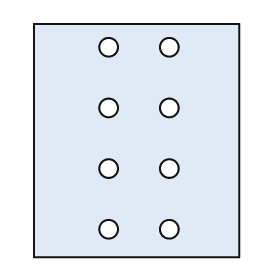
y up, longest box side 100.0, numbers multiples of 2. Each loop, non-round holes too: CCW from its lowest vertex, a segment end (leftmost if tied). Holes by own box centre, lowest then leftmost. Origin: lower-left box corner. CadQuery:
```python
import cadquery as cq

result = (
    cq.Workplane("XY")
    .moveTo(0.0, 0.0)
    .lineTo(88.0, 0.0)
    .lineTo(88.0, 100.0)
    .lineTo(0.0, 100.0)
    .close()
    .moveTo(32.0, 12.0)
    .circle(4.0)
    .moveTo(58.0, 12.0)
    .circle(4.0)
    .moveTo(32.0, 38.0)
    .circle(4.0)
    .moveTo(58.0, 38.0)
    .circle(4.0)
    .moveTo(32.0, 64.0)
    .circle(4.0)
    .moveTo(58.0, 64.0)
    .circle(4.0)
    .moveTo(32.0, 90.0)
    .circle(4.0)
    .moveTo(58.0, 90.0)
    .circle(4.0)
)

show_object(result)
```